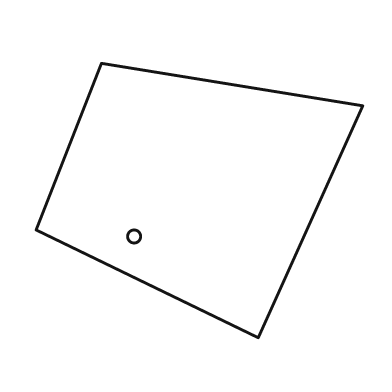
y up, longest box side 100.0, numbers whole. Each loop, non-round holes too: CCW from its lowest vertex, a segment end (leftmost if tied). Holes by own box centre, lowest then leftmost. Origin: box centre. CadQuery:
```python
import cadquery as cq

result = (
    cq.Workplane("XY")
    .moveTo(18.0, -42.0)
    .lineTo(50.0, 29.0)
    .lineTo(-30.0, 42.0)
    .lineTo(-50.0, -9.0)
    .close()
    .moveTo(-20.0, -11.0)
    .circle(2.0)
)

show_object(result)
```